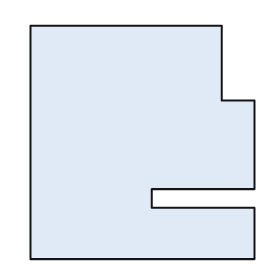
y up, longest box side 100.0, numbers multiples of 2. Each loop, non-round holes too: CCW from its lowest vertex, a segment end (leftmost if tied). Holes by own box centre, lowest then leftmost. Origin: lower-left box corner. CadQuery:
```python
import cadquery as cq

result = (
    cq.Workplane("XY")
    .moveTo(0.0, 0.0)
    .lineTo(96.0, 0.0)
    .lineTo(96.0, 22.0)
    .lineTo(52.0, 22.0)
    .lineTo(52.0, 30.0)
    .lineTo(96.0, 30.0)
    .lineTo(96.0, 68.0)
    .lineTo(82.0, 68.0)
    .lineTo(82.0, 100.0)
    .lineTo(0.0, 100.0)
    .close()
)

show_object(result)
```